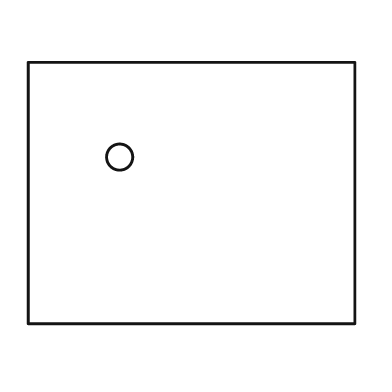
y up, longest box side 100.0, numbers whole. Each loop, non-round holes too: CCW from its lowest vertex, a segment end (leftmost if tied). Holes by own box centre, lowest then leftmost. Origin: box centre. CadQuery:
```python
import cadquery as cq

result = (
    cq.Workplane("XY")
    .moveTo(-50.0, -40.0)
    .lineTo(50.0, -40.0)
    .lineTo(50.0, 40.0)
    .lineTo(-50.0, 40.0)
    .close()
    .moveTo(-22.0, 11.0)
    .circle(4.0)
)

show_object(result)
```